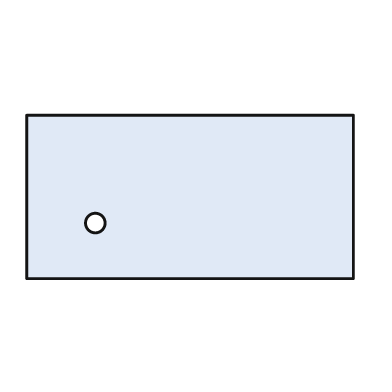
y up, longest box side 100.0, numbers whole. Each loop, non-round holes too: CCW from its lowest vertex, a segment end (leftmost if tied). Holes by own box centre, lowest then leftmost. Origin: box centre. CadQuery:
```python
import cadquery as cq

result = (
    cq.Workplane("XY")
    .moveTo(-50.0, -25.0)
    .lineTo(50.0, -25.0)
    .lineTo(50.0, 25.0)
    .lineTo(-50.0, 25.0)
    .close()
    .moveTo(-29.0, -8.0)
    .circle(3.0)
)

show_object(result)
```